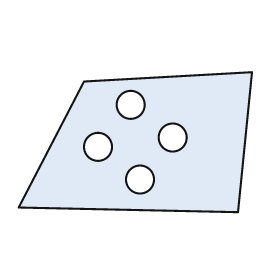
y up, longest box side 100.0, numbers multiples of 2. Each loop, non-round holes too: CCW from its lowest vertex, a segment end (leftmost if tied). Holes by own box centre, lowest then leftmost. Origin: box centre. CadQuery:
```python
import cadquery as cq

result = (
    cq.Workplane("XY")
    .moveTo(44.0, -30.0)
    .lineTo(50.0, 30.0)
    .lineTo(-22.0, 26.0)
    .lineTo(-50.0, -28.0)
    .close()
    .moveTo(2.0, -16.0)
    .circle(6.0)
    .moveTo(-16.0, -2.0)
    .circle(6.0)
    .moveTo(16.0, 2.0)
    .circle(6.0)
    .moveTo(-2.0, 16.0)
    .circle(6.0)
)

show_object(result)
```